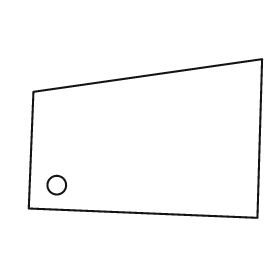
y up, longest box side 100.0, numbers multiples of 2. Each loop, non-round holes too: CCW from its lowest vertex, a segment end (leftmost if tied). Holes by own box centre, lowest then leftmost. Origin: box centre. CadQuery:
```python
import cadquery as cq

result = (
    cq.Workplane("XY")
    .moveTo(48.0, -34.0)
    .lineTo(50.0, 34.0)
    .lineTo(-48.0, 20.0)
    .lineTo(-50.0, -30.0)
    .close()
    .moveTo(-38.0, -20.0)
    .circle(4.0)
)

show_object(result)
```